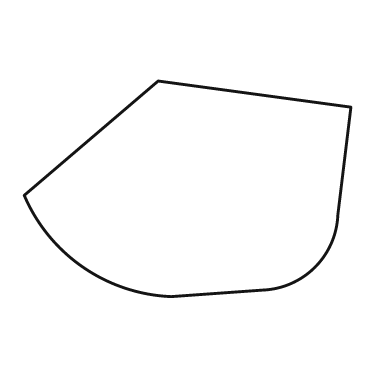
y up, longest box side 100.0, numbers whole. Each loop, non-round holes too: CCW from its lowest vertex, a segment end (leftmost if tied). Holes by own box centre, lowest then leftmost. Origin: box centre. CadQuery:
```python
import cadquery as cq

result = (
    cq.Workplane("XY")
    .moveTo(-5.0, -33.0)
    .lineTo(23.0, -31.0)
    .threePointArc((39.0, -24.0), (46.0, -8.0))
    .lineTo(50.0, 25.0)
    .lineTo(-9.0, 33.0)
    .lineTo(-50.0, -2.0)
    .threePointArc((-32.0, -24.0), (-5.0, -33.0))
    .close()
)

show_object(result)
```